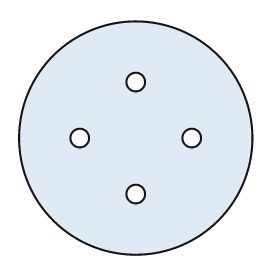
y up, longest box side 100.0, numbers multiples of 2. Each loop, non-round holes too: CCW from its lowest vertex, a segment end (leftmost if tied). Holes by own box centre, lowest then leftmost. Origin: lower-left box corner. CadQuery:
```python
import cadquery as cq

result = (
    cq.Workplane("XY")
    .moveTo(50.0, 50.0)
    .circle(50.0)
    .moveTo(50.0, 26.0)
    .circle(4.0)
    .moveTo(26.0, 50.0)
    .circle(4.0)
    .moveTo(74.0, 50.0)
    .circle(4.0)
    .moveTo(50.0, 74.0)
    .circle(4.0)
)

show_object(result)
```